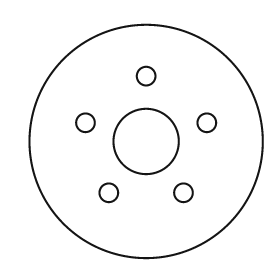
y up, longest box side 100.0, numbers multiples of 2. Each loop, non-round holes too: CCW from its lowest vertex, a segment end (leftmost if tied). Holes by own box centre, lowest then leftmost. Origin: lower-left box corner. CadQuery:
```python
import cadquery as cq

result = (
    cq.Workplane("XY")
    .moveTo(50.0, 50.0)
    .circle(50.0)
    .moveTo(34.0, 28.0)
    .circle(4.0)
    .moveTo(66.0, 28.0)
    .circle(4.0)
    .moveTo(50.0, 50.0)
    .circle(14.0)
    .moveTo(24.0, 58.0)
    .circle(4.0)
    .moveTo(76.0, 58.0)
    .circle(4.0)
    .moveTo(50.0, 78.0)
    .circle(4.0)
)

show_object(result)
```